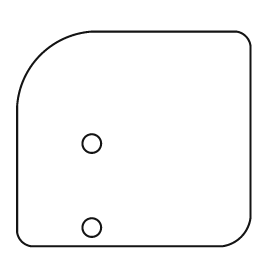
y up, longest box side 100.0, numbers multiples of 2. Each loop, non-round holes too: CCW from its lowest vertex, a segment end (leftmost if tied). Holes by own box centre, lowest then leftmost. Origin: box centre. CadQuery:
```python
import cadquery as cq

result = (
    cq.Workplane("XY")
    .moveTo(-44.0, -46.0)
    .lineTo(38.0, -46.0)
    .threePointArc((46.0, -42.0), (50.0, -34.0))
    .lineTo(50.0, 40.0)
    .threePointArc((48.0, 44.0), (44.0, 46.0))
    .lineTo(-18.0, 46.0)
    .threePointArc((-40.0, 36.0), (-50.0, 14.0))
    .lineTo(-50.0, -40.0)
    .threePointArc((-48.0, -44.0), (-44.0, -46.0))
    .close()
    .moveTo(-18.0, -38.0)
    .circle(4.0)
    .moveTo(-18.0, -2.0)
    .circle(4.0)
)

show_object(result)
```